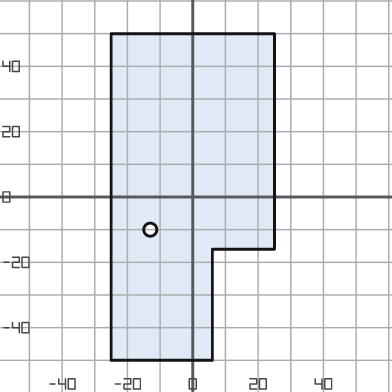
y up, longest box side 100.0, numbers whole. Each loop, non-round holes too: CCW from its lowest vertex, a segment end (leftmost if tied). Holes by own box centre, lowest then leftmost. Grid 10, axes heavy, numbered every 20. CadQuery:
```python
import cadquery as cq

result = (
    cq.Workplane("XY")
    .moveTo(-25.0, -50.0)
    .lineTo(6.0, -50.0)
    .lineTo(6.0, -16.0)
    .lineTo(25.0, -16.0)
    .lineTo(25.0, 50.0)
    .lineTo(-25.0, 50.0)
    .close()
    .moveTo(-13.0, -10.0)
    .circle(2.0)
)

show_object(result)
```